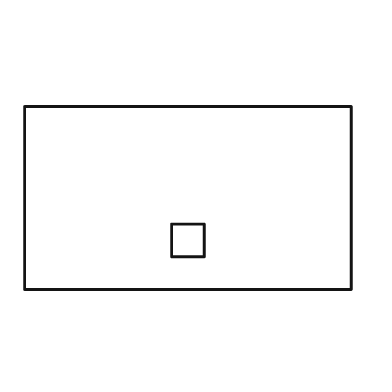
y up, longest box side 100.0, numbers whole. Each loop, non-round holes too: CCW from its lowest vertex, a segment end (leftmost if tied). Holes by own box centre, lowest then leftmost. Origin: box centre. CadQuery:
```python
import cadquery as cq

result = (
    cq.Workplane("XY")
    .moveTo(-50.0, -28.0)
    .lineTo(50.0, -28.0)
    .lineTo(50.0, 28.0)
    .lineTo(-50.0, 28.0)
    .close()
    .moveTo(-5.0, -18.0)
    .lineTo(5.0, -18.0)
    .lineTo(5.0, -8.0)
    .lineTo(-5.0, -8.0)
    .close()
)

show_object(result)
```